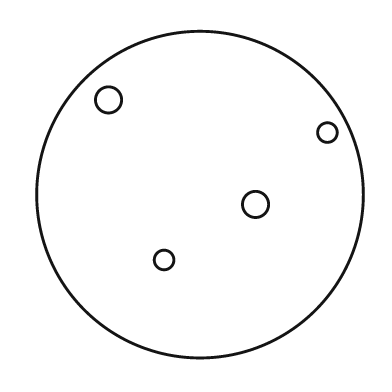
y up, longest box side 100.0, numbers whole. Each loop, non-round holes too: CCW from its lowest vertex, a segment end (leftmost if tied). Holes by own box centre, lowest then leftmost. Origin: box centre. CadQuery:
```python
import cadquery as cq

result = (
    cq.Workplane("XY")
    .moveTo(0.0, 0.0)
    .circle(50.0)
    .moveTo(-11.0, -20.0)
    .circle(3.0)
    .moveTo(17.0, -3.0)
    .circle(4.0)
    .moveTo(39.0, 19.0)
    .circle(3.0)
    .moveTo(-28.0, 29.0)
    .circle(4.0)
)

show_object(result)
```